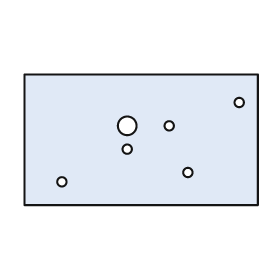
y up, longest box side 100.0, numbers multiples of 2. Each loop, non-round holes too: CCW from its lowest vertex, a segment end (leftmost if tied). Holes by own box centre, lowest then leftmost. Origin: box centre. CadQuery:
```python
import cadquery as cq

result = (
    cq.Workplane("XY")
    .moveTo(-50.0, -28.0)
    .lineTo(50.0, -28.0)
    .lineTo(50.0, 28.0)
    .lineTo(-50.0, 28.0)
    .close()
    .moveTo(-34.0, -18.0)
    .circle(2.0)
    .moveTo(20.0, -14.0)
    .circle(2.0)
    .moveTo(-6.0, -4.0)
    .circle(2.0)
    .moveTo(-6.0, 6.0)
    .circle(4.0)
    .moveTo(12.0, 6.0)
    .circle(2.0)
    .moveTo(42.0, 16.0)
    .circle(2.0)
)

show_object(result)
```